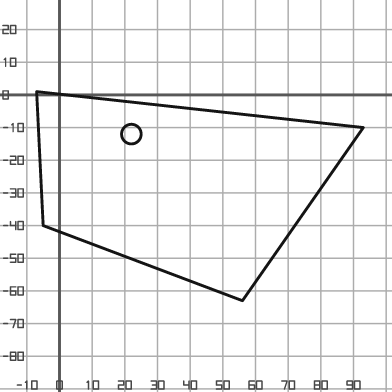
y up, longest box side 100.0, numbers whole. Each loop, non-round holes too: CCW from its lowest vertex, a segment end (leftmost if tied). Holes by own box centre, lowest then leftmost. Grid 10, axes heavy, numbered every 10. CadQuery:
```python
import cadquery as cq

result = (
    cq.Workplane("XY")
    .moveTo(56.0, -63.0)
    .lineTo(93.0, -10.0)
    .lineTo(-7.0, 1.0)
    .lineTo(-5.0, -40.0)
    .close()
    .moveTo(22.0, -12.0)
    .circle(3.0)
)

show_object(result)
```